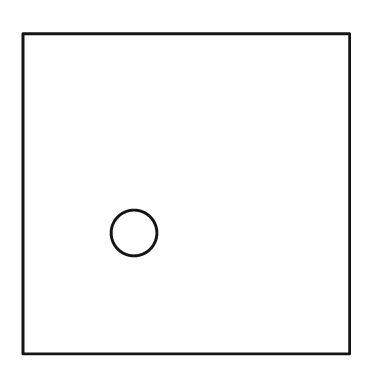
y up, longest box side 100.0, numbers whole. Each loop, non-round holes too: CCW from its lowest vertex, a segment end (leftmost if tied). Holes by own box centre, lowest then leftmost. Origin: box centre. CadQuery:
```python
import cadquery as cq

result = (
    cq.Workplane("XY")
    .moveTo(-50.0, -49.0)
    .lineTo(50.0, -49.0)
    .lineTo(50.0, 49.0)
    .lineTo(-50.0, 49.0)
    .close()
    .moveTo(-16.0, -12.0)
    .circle(7.0)
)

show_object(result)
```